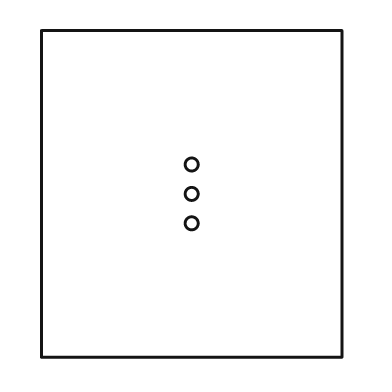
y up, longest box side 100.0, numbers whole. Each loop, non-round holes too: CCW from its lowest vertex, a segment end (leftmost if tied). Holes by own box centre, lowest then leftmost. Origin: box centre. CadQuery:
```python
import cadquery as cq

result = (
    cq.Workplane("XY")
    .moveTo(-46.0, -50.0)
    .lineTo(46.0, -50.0)
    .lineTo(46.0, 50.0)
    .lineTo(-46.0, 50.0)
    .close()
    .moveTo(0.0, -9.0)
    .circle(2.0)
    .moveTo(0.0, 0.0)
    .circle(2.0)
    .moveTo(0.0, 9.0)
    .circle(2.0)
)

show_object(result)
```